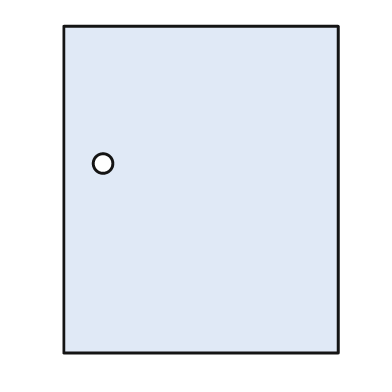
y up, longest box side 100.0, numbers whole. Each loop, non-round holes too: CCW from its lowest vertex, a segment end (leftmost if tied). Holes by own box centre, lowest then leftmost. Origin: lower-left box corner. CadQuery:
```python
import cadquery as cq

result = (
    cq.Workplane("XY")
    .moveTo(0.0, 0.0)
    .lineTo(84.0, 0.0)
    .lineTo(84.0, 100.0)
    .lineTo(0.0, 100.0)
    .close()
    .moveTo(12.0, 58.0)
    .circle(3.0)
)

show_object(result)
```